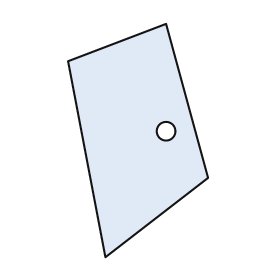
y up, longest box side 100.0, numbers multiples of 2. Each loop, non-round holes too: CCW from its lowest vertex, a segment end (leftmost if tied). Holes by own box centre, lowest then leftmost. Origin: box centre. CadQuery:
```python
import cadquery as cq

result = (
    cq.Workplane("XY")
    .moveTo(-14.0, -50.0)
    .lineTo(30.0, -16.0)
    .lineTo(12.0, 50.0)
    .lineTo(-30.0, 34.0)
    .close()
    .moveTo(12.0, 4.0)
    .circle(4.0)
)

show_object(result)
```